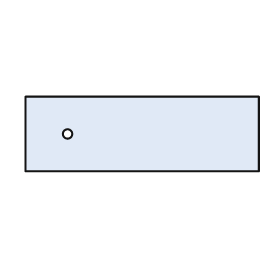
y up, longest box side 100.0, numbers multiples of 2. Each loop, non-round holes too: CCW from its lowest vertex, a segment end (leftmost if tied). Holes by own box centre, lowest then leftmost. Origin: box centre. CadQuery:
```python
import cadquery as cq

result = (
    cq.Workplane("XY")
    .moveTo(-50.0, -16.0)
    .lineTo(50.0, -16.0)
    .lineTo(50.0, 16.0)
    .lineTo(-50.0, 16.0)
    .close()
    .moveTo(-32.0, 0.0)
    .circle(2.0)
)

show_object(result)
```